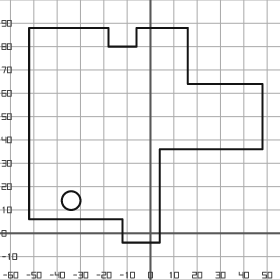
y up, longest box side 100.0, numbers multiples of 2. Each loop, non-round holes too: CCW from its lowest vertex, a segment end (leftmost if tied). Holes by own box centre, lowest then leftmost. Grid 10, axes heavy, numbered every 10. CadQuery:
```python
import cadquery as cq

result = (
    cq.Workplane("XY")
    .moveTo(-12.0, -4.0)
    .lineTo(4.0, -4.0)
    .lineTo(4.0, 36.0)
    .lineTo(48.0, 36.0)
    .lineTo(48.0, 64.0)
    .lineTo(16.0, 64.0)
    .lineTo(16.0, 88.0)
    .lineTo(-6.0, 88.0)
    .lineTo(-6.0, 80.0)
    .lineTo(-18.0, 80.0)
    .lineTo(-18.0, 88.0)
    .lineTo(-52.0, 88.0)
    .lineTo(-52.0, 6.0)
    .lineTo(-12.0, 6.0)
    .close()
    .moveTo(-34.0, 14.0)
    .circle(4.0)
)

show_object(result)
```